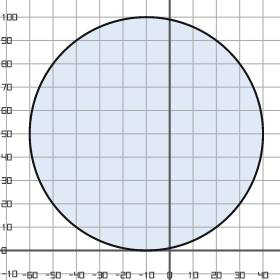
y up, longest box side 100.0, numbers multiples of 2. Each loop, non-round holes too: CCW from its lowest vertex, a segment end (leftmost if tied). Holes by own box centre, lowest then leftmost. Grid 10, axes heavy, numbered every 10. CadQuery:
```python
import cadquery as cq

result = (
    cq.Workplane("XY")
    .moveTo(-10.0, 50.0)
    .circle(50.0)
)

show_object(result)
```